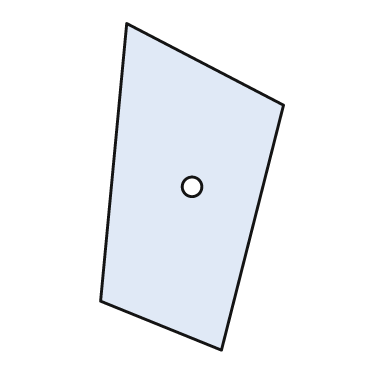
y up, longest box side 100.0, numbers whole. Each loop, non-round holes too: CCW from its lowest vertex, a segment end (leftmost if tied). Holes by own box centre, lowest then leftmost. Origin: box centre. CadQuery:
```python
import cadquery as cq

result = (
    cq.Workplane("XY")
    .moveTo(9.0, -50.0)
    .lineTo(28.0, 25.0)
    .lineTo(-20.0, 50.0)
    .lineTo(-28.0, -35.0)
    .close()
    .moveTo(0.0, 0.0)
    .circle(3.0)
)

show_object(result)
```